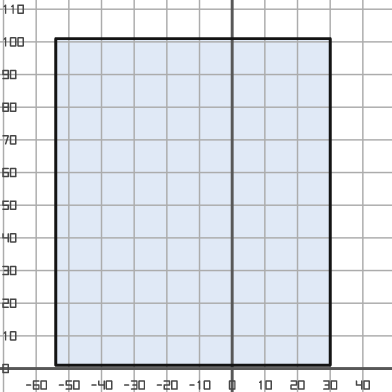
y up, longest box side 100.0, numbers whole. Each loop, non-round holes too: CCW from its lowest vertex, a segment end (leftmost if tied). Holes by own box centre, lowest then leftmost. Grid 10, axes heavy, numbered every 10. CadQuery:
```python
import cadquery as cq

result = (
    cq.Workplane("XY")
    .moveTo(-54.0, 1.0)
    .lineTo(30.0, 1.0)
    .lineTo(30.0, 101.0)
    .lineTo(-54.0, 101.0)
    .close()
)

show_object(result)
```